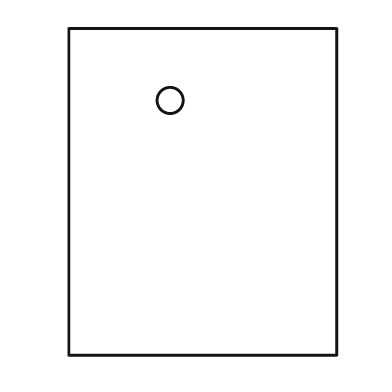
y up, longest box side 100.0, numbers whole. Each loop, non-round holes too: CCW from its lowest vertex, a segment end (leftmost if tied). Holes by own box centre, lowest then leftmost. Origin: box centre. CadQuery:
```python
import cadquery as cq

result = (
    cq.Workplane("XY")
    .moveTo(-41.0, -50.0)
    .lineTo(41.0, -50.0)
    .lineTo(41.0, 50.0)
    .lineTo(-41.0, 50.0)
    .close()
    .moveTo(-10.0, 28.0)
    .circle(4.0)
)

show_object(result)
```